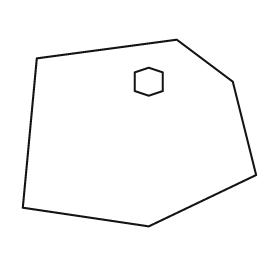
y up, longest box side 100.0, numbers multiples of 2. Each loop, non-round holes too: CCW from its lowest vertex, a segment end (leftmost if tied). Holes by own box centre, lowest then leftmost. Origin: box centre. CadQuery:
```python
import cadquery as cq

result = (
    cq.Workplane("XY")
    .moveTo(4.0, -40.0)
    .lineTo(50.0, -18.0)
    .lineTo(40.0, 22.0)
    .lineTo(16.0, 40.0)
    .lineTo(-44.0, 32.0)
    .lineTo(-50.0, -32.0)
    .close()
    .moveTo(4.0, 16.0)
    .lineTo(10.0, 18.0)
    .lineTo(10.0, 26.0)
    .lineTo(4.0, 28.0)
    .lineTo(-2.0, 26.0)
    .lineTo(-2.0, 18.0)
    .close()
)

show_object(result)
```